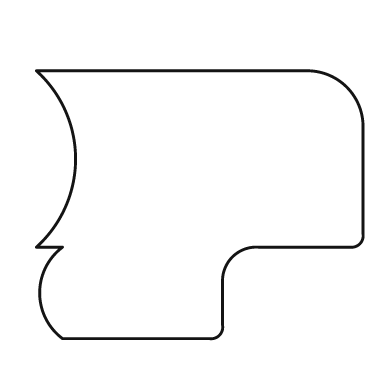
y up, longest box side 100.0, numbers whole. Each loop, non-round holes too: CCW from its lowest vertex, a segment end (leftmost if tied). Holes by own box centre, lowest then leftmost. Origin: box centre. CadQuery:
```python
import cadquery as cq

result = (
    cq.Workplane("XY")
    .moveTo(-42.0, -41.0)
    .lineTo(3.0, -41.0)
    .threePointArc((6.0, -40.0), (7.0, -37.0))
    .lineTo(7.0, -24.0)
    .threePointArc((10.0, -16.0), (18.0, -13.0))
    .lineTo(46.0, -13.0)
    .threePointArc((49.0, -12.0), (50.0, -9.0))
    .lineTo(50.0, 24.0)
    .threePointArc((45.0, 36.0), (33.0, 41.0))
    .lineTo(-50.0, 41.0)
    .threePointArc((-38.0, 14.0), (-50.0, -13.0))
    .lineTo(-42.0, -13.0)
    .threePointArc((-49.0, -27.0), (-42.0, -41.0))
    .close()
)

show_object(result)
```